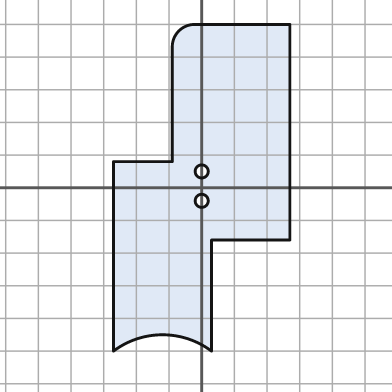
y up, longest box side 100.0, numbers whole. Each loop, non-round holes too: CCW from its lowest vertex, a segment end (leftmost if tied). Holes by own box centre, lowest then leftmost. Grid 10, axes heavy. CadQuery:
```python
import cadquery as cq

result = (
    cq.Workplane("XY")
    .moveTo(-27.0, -50.0)
    .threePointArc((-12.0, -45.0), (3.0, -50.0))
    .lineTo(3.0, -16.0)
    .lineTo(27.0, -16.0)
    .lineTo(27.0, 50.0)
    .lineTo(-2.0, 50.0)
    .threePointArc((-7.0, 48.0), (-9.0, 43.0))
    .lineTo(-9.0, 8.0)
    .lineTo(-27.0, 8.0)
    .close()
    .moveTo(0.0, -4.0)
    .circle(2.0)
    .moveTo(0.0, 5.0)
    .circle(2.0)
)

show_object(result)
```